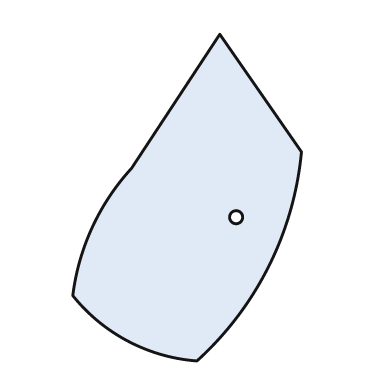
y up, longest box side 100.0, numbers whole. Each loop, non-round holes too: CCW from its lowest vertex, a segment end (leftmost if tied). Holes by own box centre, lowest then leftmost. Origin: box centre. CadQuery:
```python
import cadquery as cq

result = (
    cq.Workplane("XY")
    .moveTo(3.0, -50.0)
    .threePointArc((25.0, -21.0), (35.0, 14.0))
    .lineTo(10.0, 50.0)
    .lineTo(-17.0, 9.0)
    .threePointArc((-29.0, -9.0), (-35.0, -30.0))
    .threePointArc((-18.0, -44.0), (3.0, -50.0))
    .close()
    .moveTo(15.0, -6.0)
    .circle(2.0)
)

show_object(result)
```